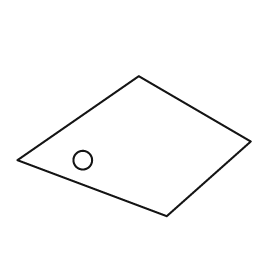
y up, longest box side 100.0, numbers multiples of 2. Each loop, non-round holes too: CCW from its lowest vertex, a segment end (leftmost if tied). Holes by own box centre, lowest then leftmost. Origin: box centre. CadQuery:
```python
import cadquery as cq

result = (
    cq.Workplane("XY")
    .moveTo(14.0, -30.0)
    .lineTo(50.0, 2.0)
    .lineTo(2.0, 30.0)
    .lineTo(-50.0, -6.0)
    .close()
    .moveTo(-22.0, -6.0)
    .circle(4.0)
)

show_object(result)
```